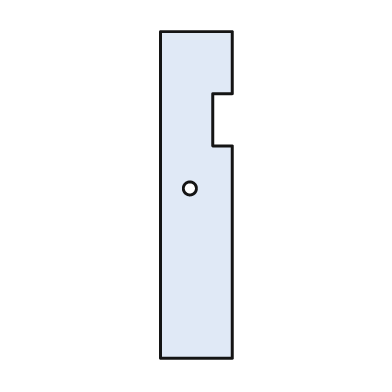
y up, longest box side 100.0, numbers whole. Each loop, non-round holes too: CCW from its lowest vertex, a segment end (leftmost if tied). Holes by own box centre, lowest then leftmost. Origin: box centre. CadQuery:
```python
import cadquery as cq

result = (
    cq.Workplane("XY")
    .moveTo(-11.0, -50.0)
    .lineTo(11.0, -50.0)
    .lineTo(11.0, 15.0)
    .lineTo(5.0, 15.0)
    .lineTo(5.0, 31.0)
    .lineTo(11.0, 31.0)
    .lineTo(11.0, 50.0)
    .lineTo(-11.0, 50.0)
    .close()
    .moveTo(-2.0, 2.0)
    .circle(2.0)
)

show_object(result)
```